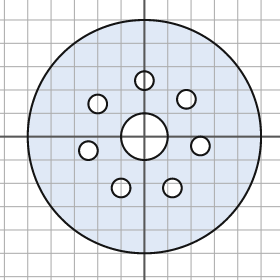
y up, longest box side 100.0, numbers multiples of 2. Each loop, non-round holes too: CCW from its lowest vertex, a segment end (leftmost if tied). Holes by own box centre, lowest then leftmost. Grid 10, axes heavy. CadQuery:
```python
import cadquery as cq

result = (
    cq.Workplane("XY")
    .moveTo(0.0, 0.0)
    .circle(50.0)
    .moveTo(-10.0, -22.0)
    .circle(4.0)
    .moveTo(12.0, -22.0)
    .circle(4.0)
    .moveTo(-24.0, -6.0)
    .circle(4.0)
    .moveTo(24.0, -4.0)
    .circle(4.0)
    .moveTo(0.0, 0.0)
    .circle(10.0)
    .moveTo(-20.0, 14.0)
    .circle(4.0)
    .moveTo(18.0, 16.0)
    .circle(4.0)
    .moveTo(0.0, 24.0)
    .circle(4.0)
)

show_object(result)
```